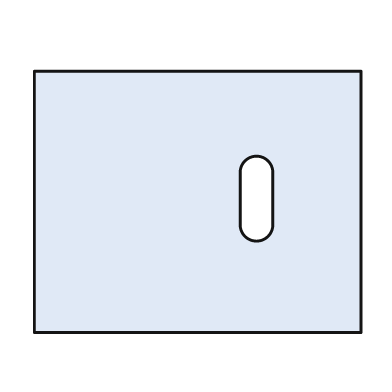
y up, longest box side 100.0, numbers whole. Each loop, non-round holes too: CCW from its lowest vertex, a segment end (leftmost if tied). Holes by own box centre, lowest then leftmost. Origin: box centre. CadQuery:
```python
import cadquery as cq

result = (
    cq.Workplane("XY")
    .moveTo(-50.0, -40.0)
    .lineTo(50.0, -40.0)
    .lineTo(50.0, 40.0)
    .lineTo(-50.0, 40.0)
    .close()
    .moveTo(13.0, -7.0)
    .threePointArc((18.0, -12.0), (23.0, -7.0))
    .lineTo(23.0, 9.0)
    .threePointArc((18.0, 14.0), (13.0, 9.0))
    .close()
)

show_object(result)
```